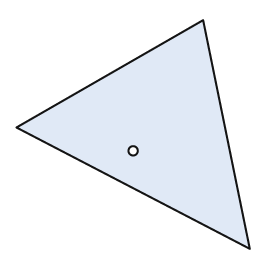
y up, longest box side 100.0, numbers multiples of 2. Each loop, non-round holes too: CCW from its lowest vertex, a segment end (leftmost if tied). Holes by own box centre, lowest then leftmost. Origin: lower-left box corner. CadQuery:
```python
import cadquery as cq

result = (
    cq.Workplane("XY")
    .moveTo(100.0, 0.0)
    .lineTo(80.0, 98.0)
    .lineTo(0.0, 52.0)
    .close()
    .moveTo(50.0, 42.0)
    .circle(2.0)
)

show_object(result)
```